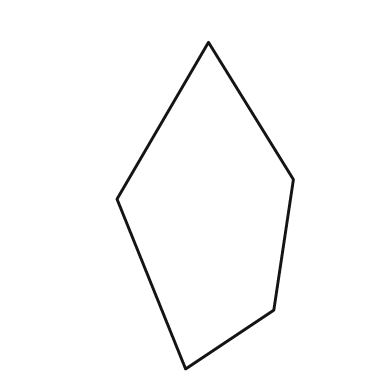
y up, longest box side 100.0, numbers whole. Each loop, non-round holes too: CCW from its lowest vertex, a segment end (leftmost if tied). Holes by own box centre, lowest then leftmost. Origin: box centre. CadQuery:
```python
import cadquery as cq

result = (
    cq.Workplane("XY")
    .moveTo(-6.0, -50.0)
    .lineTo(21.0, -32.0)
    .lineTo(27.0, 8.0)
    .lineTo(1.0, 50.0)
    .lineTo(-27.0, 2.0)
    .close()
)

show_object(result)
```